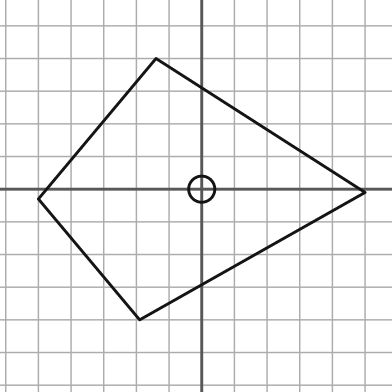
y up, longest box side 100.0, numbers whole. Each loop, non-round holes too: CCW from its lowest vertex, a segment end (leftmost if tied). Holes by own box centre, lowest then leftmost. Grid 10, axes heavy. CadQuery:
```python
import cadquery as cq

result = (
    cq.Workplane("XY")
    .moveTo(-19.0, -40.0)
    .lineTo(50.0, -1.0)
    .lineTo(-14.0, 40.0)
    .lineTo(-50.0, -3.0)
    .close()
    .moveTo(0.0, 0.0)
    .circle(4.0)
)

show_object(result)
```